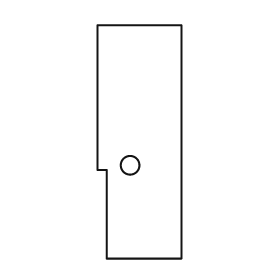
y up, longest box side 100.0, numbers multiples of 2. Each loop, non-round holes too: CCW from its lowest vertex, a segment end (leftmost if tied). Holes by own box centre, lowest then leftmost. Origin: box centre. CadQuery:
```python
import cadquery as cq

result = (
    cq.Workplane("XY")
    .moveTo(-14.0, -50.0)
    .lineTo(18.0, -50.0)
    .lineTo(18.0, 50.0)
    .lineTo(-18.0, 50.0)
    .lineTo(-18.0, -12.0)
    .lineTo(-14.0, -12.0)
    .close()
    .moveTo(-4.0, -10.0)
    .circle(4.0)
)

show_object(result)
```